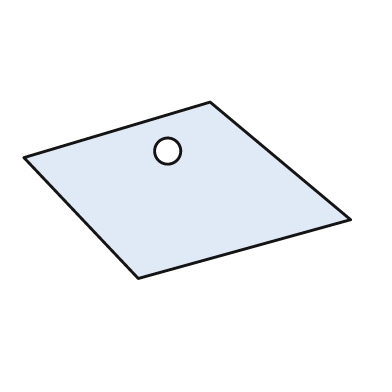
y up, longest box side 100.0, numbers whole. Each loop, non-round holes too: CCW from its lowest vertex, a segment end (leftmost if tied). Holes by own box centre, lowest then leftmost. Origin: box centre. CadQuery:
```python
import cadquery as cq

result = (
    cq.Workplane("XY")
    .moveTo(-15.0, -27.0)
    .lineTo(50.0, -9.0)
    .lineTo(7.0, 27.0)
    .lineTo(-50.0, 10.0)
    .close()
    .moveTo(-6.0, 12.0)
    .circle(4.0)
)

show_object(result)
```